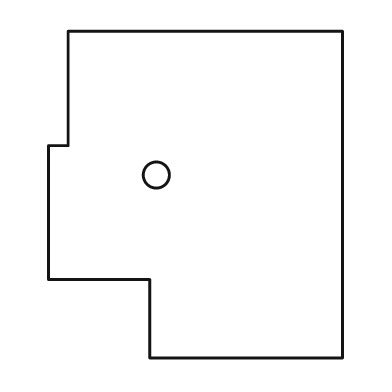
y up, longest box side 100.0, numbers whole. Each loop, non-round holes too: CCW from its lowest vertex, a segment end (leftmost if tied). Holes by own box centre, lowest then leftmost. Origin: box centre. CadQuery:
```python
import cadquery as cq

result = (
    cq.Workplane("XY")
    .moveTo(-14.0, -50.0)
    .lineTo(45.0, -50.0)
    .lineTo(45.0, 50.0)
    .lineTo(-39.0, 50.0)
    .lineTo(-39.0, 15.0)
    .lineTo(-45.0, 15.0)
    .lineTo(-45.0, -26.0)
    .lineTo(-14.0, -26.0)
    .close()
    .moveTo(-12.0, 6.0)
    .circle(4.0)
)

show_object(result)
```